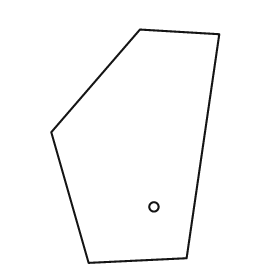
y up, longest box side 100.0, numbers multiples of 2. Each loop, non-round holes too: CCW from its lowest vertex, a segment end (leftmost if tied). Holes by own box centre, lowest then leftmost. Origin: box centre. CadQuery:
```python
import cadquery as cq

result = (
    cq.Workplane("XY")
    .moveTo(-20.0, -50.0)
    .lineTo(22.0, -48.0)
    .lineTo(36.0, 48.0)
    .lineTo(2.0, 50.0)
    .lineTo(-36.0, 6.0)
    .close()
    .moveTo(8.0, -26.0)
    .circle(2.0)
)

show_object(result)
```